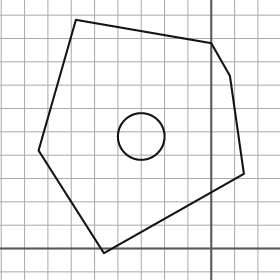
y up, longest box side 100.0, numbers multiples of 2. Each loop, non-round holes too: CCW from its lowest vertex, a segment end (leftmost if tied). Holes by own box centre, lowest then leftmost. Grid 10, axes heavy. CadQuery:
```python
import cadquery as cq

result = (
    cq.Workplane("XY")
    .moveTo(-46.0, -2.0)
    .lineTo(14.0, 32.0)
    .lineTo(8.0, 74.0)
    .lineTo(0.0, 88.0)
    .lineTo(-58.0, 98.0)
    .lineTo(-74.0, 42.0)
    .close()
    .moveTo(-30.0, 48.0)
    .circle(10.0)
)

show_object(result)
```